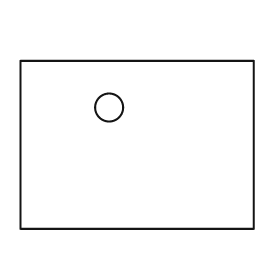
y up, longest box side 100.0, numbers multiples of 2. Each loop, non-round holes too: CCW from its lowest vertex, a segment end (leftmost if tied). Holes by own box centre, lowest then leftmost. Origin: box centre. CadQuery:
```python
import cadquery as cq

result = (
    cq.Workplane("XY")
    .moveTo(-50.0, -36.0)
    .lineTo(50.0, -36.0)
    .lineTo(50.0, 36.0)
    .lineTo(-50.0, 36.0)
    .close()
    .moveTo(-12.0, 16.0)
    .circle(6.0)
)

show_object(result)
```